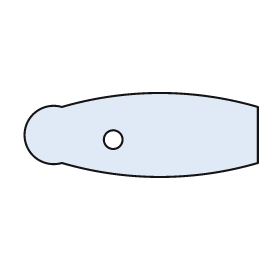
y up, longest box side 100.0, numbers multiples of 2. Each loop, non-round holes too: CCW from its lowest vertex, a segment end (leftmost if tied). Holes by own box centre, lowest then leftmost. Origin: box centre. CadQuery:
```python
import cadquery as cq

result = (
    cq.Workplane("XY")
    .moveTo(-34.0, -12.0)
    .threePointArc((8.0, -18.0), (50.0, -12.0))
    .lineTo(50.0, 12.0)
    .threePointArc((8.0, 18.0), (-34.0, 12.0))
    .threePointArc((-50.0, 0.0), (-34.0, -12.0))
    .close()
    .moveTo(-12.0, -2.0)
    .circle(4.0)
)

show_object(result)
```